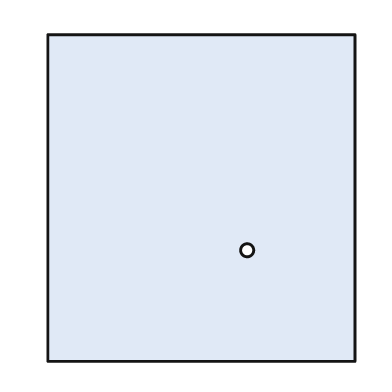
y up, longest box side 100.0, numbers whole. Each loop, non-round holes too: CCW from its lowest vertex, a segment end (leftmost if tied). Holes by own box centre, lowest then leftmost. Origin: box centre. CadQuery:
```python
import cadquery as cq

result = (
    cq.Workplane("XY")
    .moveTo(-47.0, -50.0)
    .lineTo(47.0, -50.0)
    .lineTo(47.0, 50.0)
    .lineTo(-47.0, 50.0)
    .close()
    .moveTo(14.0, -16.0)
    .circle(2.0)
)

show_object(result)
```